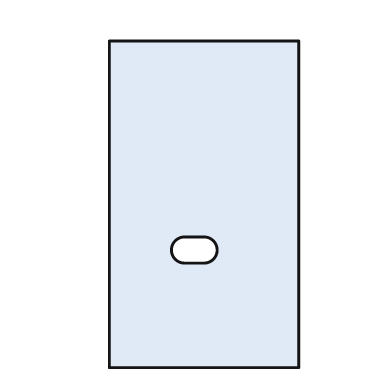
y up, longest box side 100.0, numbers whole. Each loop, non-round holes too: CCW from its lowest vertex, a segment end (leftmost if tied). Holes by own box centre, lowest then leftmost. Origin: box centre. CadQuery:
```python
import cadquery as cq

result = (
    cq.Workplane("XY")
    .moveTo(-29.0, -50.0)
    .lineTo(29.0, -50.0)
    .lineTo(29.0, 50.0)
    .lineTo(-29.0, 50.0)
    .close()
    .moveTo(-6.0, -18.0)
    .lineTo(0.0, -18.0)
    .threePointArc((4.0, -14.0), (0.0, -10.0))
    .lineTo(-6.0, -10.0)
    .threePointArc((-10.0, -14.0), (-6.0, -18.0))
    .close()
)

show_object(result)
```